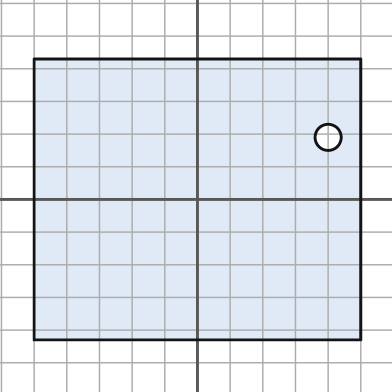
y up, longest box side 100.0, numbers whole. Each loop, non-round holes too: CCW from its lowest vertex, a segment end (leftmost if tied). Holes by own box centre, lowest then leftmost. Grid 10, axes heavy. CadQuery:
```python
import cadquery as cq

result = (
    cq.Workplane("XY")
    .moveTo(-50.0, -43.0)
    .lineTo(50.0, -43.0)
    .lineTo(50.0, 43.0)
    .lineTo(-50.0, 43.0)
    .close()
    .moveTo(40.0, 19.0)
    .circle(4.0)
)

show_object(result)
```